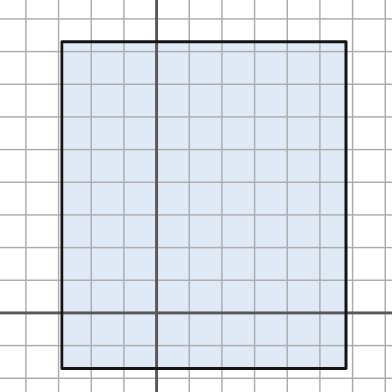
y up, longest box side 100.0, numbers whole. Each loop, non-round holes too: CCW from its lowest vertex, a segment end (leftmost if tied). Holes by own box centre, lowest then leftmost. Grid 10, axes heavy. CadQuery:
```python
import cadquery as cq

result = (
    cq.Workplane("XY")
    .moveTo(-29.0, -17.0)
    .lineTo(58.0, -17.0)
    .lineTo(58.0, 83.0)
    .lineTo(-29.0, 83.0)
    .close()
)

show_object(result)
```